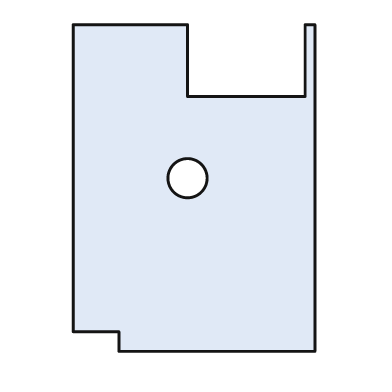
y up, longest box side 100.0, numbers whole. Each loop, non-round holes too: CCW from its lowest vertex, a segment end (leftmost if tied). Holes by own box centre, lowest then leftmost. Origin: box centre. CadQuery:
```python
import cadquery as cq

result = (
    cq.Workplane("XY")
    .moveTo(-23.0, -50.0)
    .lineTo(37.0, -50.0)
    .lineTo(37.0, 50.0)
    .lineTo(34.0, 50.0)
    .lineTo(34.0, 28.0)
    .lineTo(-2.0, 28.0)
    .lineTo(-2.0, 50.0)
    .lineTo(-37.0, 50.0)
    .lineTo(-37.0, -44.0)
    .lineTo(-23.0, -44.0)
    .close()
    .moveTo(-2.0, 3.0)
    .circle(6.0)
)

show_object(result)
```